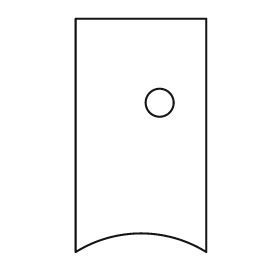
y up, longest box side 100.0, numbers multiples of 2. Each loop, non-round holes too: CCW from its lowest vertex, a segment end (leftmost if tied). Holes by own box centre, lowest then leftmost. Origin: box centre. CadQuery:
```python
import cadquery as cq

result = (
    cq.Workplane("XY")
    .moveTo(-28.0, -50.0)
    .threePointArc((0.0, -42.0), (28.0, -50.0))
    .lineTo(28.0, 50.0)
    .lineTo(-28.0, 50.0)
    .close()
    .moveTo(8.0, 14.0)
    .circle(6.0)
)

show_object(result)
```